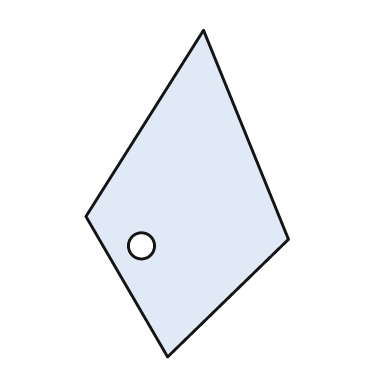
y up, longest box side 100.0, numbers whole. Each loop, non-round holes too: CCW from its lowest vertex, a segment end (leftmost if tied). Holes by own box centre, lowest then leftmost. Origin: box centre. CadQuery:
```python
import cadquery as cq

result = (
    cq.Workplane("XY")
    .moveTo(-6.0, -50.0)
    .lineTo(31.0, -14.0)
    .lineTo(5.0, 50.0)
    .lineTo(-31.0, -7.0)
    .close()
    .moveTo(-14.0, -16.0)
    .circle(4.0)
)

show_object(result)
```